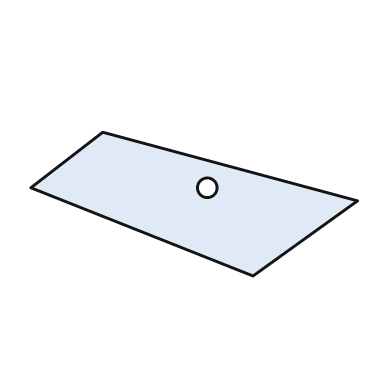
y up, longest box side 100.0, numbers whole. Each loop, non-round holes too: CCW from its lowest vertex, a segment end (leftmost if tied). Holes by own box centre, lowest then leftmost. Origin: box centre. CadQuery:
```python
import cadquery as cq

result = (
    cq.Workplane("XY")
    .moveTo(18.0, -22.0)
    .lineTo(50.0, 1.0)
    .lineTo(-28.0, 22.0)
    .lineTo(-50.0, 5.0)
    .close()
    .moveTo(4.0, 5.0)
    .circle(3.0)
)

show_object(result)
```